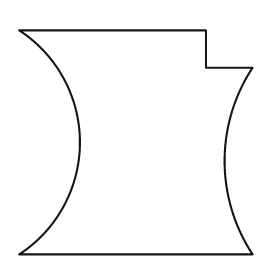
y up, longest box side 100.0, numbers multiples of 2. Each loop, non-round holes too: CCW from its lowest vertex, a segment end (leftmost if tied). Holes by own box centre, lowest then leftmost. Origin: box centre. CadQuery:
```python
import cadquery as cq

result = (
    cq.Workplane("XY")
    .moveTo(-50.0, -48.0)
    .lineTo(50.0, -48.0)
    .threePointArc((38.0, -8.0), (50.0, 32.0))
    .lineTo(30.0, 32.0)
    .lineTo(30.0, 48.0)
    .lineTo(-50.0, 48.0)
    .threePointArc((-24.0, 0.0), (-50.0, -48.0))
    .close()
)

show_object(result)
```